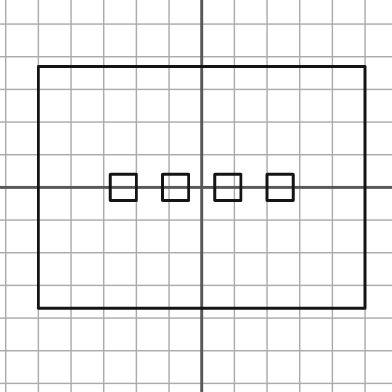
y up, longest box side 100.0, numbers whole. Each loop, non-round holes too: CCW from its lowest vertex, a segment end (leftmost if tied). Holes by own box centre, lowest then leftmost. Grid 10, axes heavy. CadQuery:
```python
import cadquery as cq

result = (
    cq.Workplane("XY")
    .moveTo(-50.0, -37.0)
    .lineTo(50.0, -37.0)
    .lineTo(50.0, 37.0)
    .lineTo(-50.0, 37.0)
    .close()
    .moveTo(-28.0, -4.0)
    .lineTo(-20.0, -4.0)
    .lineTo(-20.0, 4.0)
    .lineTo(-28.0, 4.0)
    .close()
    .moveTo(-12.0, -4.0)
    .lineTo(-4.0, -4.0)
    .lineTo(-4.0, 4.0)
    .lineTo(-12.0, 4.0)
    .close()
    .moveTo(4.0, -4.0)
    .lineTo(12.0, -4.0)
    .lineTo(12.0, 4.0)
    .lineTo(4.0, 4.0)
    .close()
    .moveTo(20.0, -4.0)
    .lineTo(28.0, -4.0)
    .lineTo(28.0, 4.0)
    .lineTo(20.0, 4.0)
    .close()
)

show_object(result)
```